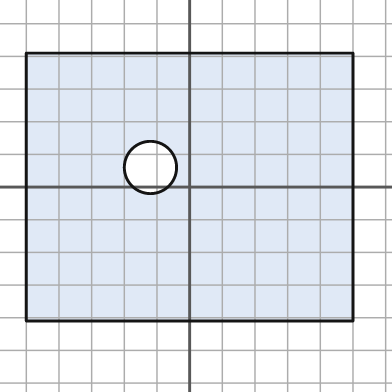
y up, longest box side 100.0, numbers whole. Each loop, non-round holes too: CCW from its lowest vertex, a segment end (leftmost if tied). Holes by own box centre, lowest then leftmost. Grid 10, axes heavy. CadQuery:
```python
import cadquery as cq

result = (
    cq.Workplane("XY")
    .moveTo(-50.0, -41.0)
    .lineTo(50.0, -41.0)
    .lineTo(50.0, 41.0)
    .lineTo(-50.0, 41.0)
    .close()
    .moveTo(-12.0, 6.0)
    .circle(8.0)
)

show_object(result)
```